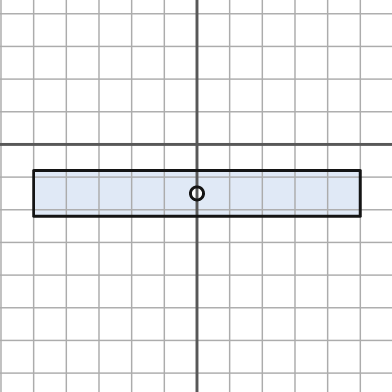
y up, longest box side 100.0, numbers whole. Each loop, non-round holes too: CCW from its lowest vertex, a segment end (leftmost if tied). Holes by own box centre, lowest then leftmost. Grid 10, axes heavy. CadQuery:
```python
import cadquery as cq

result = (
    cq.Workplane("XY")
    .moveTo(-50.0, -22.0)
    .lineTo(50.0, -22.0)
    .lineTo(50.0, -8.0)
    .lineTo(-50.0, -8.0)
    .close()
    .moveTo(0.0, -15.0)
    .circle(2.0)
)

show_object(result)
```